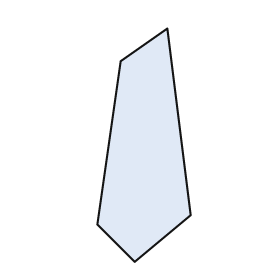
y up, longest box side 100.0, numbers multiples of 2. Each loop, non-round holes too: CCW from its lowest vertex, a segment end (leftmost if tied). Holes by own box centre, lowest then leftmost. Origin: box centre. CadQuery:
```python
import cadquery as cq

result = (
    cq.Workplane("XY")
    .moveTo(-4.0, -50.0)
    .lineTo(20.0, -30.0)
    .lineTo(10.0, 50.0)
    .lineTo(-10.0, 36.0)
    .lineTo(-20.0, -34.0)
    .close()
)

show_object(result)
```